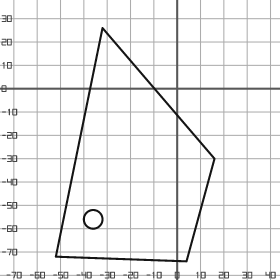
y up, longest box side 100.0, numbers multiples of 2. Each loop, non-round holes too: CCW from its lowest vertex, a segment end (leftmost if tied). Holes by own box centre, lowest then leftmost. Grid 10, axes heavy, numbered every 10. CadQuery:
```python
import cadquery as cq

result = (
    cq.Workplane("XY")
    .moveTo(4.0, -74.0)
    .lineTo(16.0, -30.0)
    .lineTo(-32.0, 26.0)
    .lineTo(-52.0, -72.0)
    .close()
    .moveTo(-36.0, -56.0)
    .circle(4.0)
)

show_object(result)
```